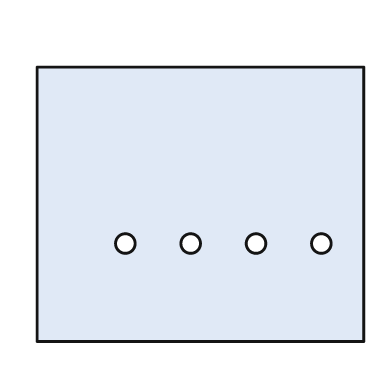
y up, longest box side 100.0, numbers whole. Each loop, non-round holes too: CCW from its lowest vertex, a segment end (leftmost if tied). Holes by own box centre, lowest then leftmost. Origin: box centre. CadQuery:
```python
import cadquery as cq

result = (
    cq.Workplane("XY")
    .moveTo(-50.0, -42.0)
    .lineTo(50.0, -42.0)
    .lineTo(50.0, 42.0)
    .lineTo(-50.0, 42.0)
    .close()
    .moveTo(-23.0, -12.0)
    .circle(3.0)
    .moveTo(-3.0, -12.0)
    .circle(3.0)
    .moveTo(17.0, -12.0)
    .circle(3.0)
    .moveTo(37.0, -12.0)
    .circle(3.0)
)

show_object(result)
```